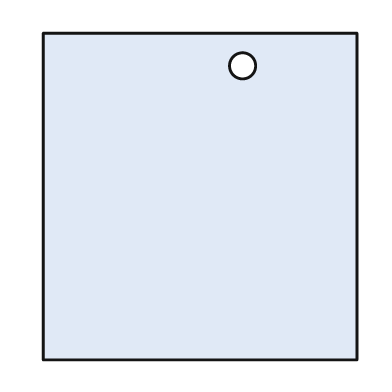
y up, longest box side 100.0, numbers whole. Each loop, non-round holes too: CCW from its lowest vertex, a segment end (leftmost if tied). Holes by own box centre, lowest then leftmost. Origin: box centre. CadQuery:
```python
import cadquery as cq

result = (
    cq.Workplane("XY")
    .moveTo(-48.0, -50.0)
    .lineTo(48.0, -50.0)
    .lineTo(48.0, 50.0)
    .lineTo(-48.0, 50.0)
    .close()
    .moveTo(13.0, 40.0)
    .circle(4.0)
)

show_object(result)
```